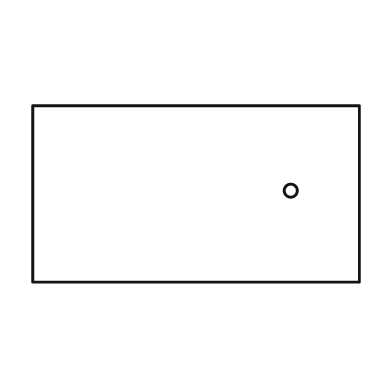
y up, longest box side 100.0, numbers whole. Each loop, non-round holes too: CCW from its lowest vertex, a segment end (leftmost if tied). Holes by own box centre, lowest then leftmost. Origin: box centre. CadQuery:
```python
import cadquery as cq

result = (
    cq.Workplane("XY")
    .moveTo(-50.0, -27.0)
    .lineTo(50.0, -27.0)
    .lineTo(50.0, 27.0)
    .lineTo(-50.0, 27.0)
    .close()
    .moveTo(29.0, 1.0)
    .circle(2.0)
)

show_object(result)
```